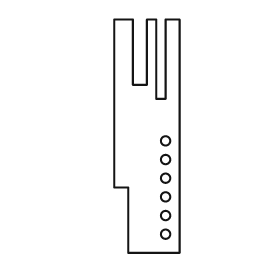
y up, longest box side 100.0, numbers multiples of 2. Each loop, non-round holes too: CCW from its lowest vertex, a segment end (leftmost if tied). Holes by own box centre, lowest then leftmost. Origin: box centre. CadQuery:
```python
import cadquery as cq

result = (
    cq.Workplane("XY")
    .moveTo(-8.0, -50.0)
    .lineTo(14.0, -50.0)
    .lineTo(14.0, 50.0)
    .lineTo(8.0, 50.0)
    .lineTo(8.0, 16.0)
    .lineTo(4.0, 16.0)
    .lineTo(4.0, 50.0)
    .lineTo(0.0, 50.0)
    .lineTo(0.0, 22.0)
    .lineTo(-6.0, 22.0)
    .lineTo(-6.0, 50.0)
    .lineTo(-14.0, 50.0)
    .lineTo(-14.0, -22.0)
    .lineTo(-8.0, -22.0)
    .close()
    .moveTo(8.0, -42.0)
    .circle(2.0)
    .moveTo(8.0, -34.0)
    .circle(2.0)
    .moveTo(8.0, -26.0)
    .circle(2.0)
    .moveTo(8.0, -18.0)
    .circle(2.0)
    .moveTo(8.0, -10.0)
    .circle(2.0)
    .moveTo(8.0, -2.0)
    .circle(2.0)
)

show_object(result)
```